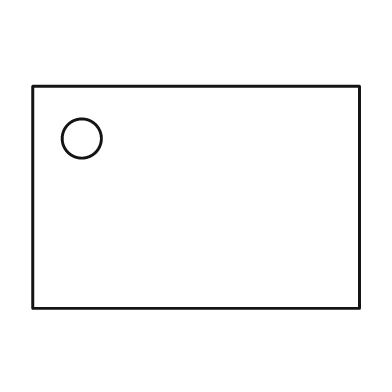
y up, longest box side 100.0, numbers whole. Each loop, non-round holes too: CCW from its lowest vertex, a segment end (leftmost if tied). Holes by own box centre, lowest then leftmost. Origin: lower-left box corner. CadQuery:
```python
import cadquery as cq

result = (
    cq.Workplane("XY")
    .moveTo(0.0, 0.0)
    .lineTo(100.0, 0.0)
    .lineTo(100.0, 68.0)
    .lineTo(0.0, 68.0)
    .close()
    .moveTo(15.0, 52.0)
    .circle(6.0)
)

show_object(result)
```